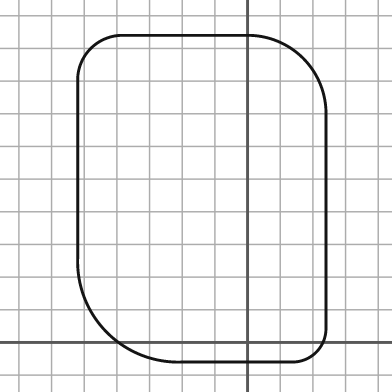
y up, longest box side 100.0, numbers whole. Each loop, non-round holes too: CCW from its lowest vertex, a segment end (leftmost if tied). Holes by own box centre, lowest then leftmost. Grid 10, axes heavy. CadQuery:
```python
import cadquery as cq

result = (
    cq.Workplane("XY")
    .moveTo(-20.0, -6.0)
    .lineTo(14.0, -6.0)
    .threePointArc((21.0, -3.0), (24.0, 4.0))
    .lineTo(24.0, 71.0)
    .threePointArc((17.0, 87.0), (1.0, 94.0))
    .lineTo(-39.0, 94.0)
    .threePointArc((-48.0, 90.0), (-52.0, 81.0))
    .lineTo(-52.0, 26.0)
    .threePointArc((-43.0, 3.0), (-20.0, -6.0))
    .close()
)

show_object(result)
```